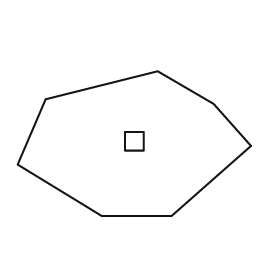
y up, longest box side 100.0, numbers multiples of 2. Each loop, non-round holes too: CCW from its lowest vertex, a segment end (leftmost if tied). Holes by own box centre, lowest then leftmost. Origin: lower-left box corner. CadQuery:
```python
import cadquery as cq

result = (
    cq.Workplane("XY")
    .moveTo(36.0, 0.0)
    .lineTo(66.0, 0.0)
    .lineTo(100.0, 30.0)
    .lineTo(84.0, 48.0)
    .lineTo(60.0, 62.0)
    .lineTo(12.0, 50.0)
    .lineTo(0.0, 22.0)
    .close()
    .moveTo(46.0, 28.0)
    .lineTo(54.0, 28.0)
    .lineTo(54.0, 36.0)
    .lineTo(46.0, 36.0)
    .close()
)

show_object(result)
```